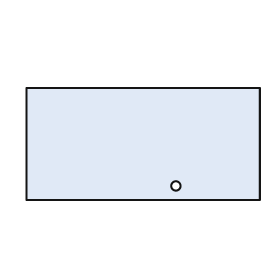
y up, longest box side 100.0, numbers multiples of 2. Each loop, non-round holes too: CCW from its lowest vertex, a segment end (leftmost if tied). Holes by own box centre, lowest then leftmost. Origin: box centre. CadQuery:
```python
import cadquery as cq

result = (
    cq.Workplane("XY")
    .moveTo(-50.0, -24.0)
    .lineTo(50.0, -24.0)
    .lineTo(50.0, 24.0)
    .lineTo(-50.0, 24.0)
    .close()
    .moveTo(14.0, -18.0)
    .circle(2.0)
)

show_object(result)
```